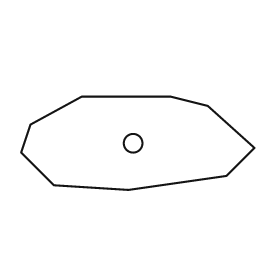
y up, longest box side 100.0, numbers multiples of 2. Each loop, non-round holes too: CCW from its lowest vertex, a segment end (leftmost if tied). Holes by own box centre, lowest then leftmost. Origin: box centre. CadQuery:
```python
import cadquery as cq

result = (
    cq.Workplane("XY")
    .moveTo(-4.0, -20.0)
    .lineTo(38.0, -14.0)
    .lineTo(50.0, -2.0)
    .lineTo(30.0, 16.0)
    .lineTo(14.0, 20.0)
    .lineTo(-24.0, 20.0)
    .lineTo(-46.0, 8.0)
    .lineTo(-50.0, -4.0)
    .lineTo(-36.0, -18.0)
    .close()
    .moveTo(-2.0, 0.0)
    .circle(4.0)
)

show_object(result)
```